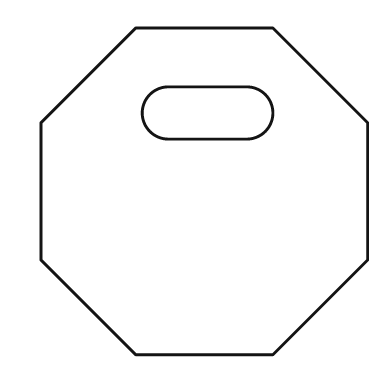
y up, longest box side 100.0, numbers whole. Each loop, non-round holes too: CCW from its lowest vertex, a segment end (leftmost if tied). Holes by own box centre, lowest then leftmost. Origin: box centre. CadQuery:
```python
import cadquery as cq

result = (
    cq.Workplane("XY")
    .moveTo(-21.0, -50.0)
    .lineTo(21.0, -50.0)
    .lineTo(50.0, -21.0)
    .lineTo(50.0, 21.0)
    .lineTo(21.0, 50.0)
    .lineTo(-21.0, 50.0)
    .lineTo(-50.0, 21.0)
    .lineTo(-50.0, -21.0)
    .close()
    .moveTo(-11.0, 16.0)
    .lineTo(13.0, 16.0)
    .threePointArc((21.0, 24.0), (13.0, 32.0))
    .lineTo(-11.0, 32.0)
    .threePointArc((-19.0, 24.0), (-11.0, 16.0))
    .close()
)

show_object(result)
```